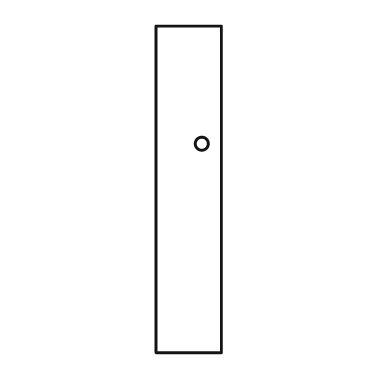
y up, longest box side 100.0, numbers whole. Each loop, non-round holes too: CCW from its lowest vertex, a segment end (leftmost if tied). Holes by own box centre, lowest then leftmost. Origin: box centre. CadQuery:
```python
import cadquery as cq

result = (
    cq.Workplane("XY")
    .moveTo(-10.0, -50.0)
    .lineTo(10.0, -50.0)
    .lineTo(10.0, 50.0)
    .lineTo(-10.0, 50.0)
    .close()
    .moveTo(4.0, 14.0)
    .circle(2.0)
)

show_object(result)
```